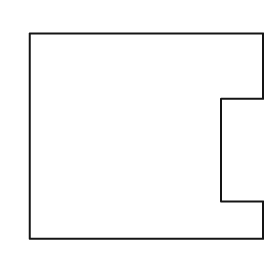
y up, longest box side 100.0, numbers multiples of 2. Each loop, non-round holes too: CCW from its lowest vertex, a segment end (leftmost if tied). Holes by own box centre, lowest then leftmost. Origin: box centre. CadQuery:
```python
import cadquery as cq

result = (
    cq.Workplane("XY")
    .moveTo(-50.0, -44.0)
    .lineTo(50.0, -44.0)
    .lineTo(50.0, -28.0)
    .lineTo(32.0, -28.0)
    .lineTo(32.0, 16.0)
    .lineTo(50.0, 16.0)
    .lineTo(50.0, 44.0)
    .lineTo(-50.0, 44.0)
    .close()
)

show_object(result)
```